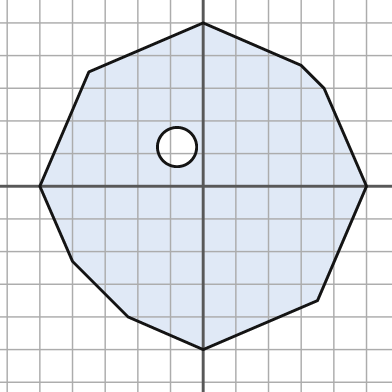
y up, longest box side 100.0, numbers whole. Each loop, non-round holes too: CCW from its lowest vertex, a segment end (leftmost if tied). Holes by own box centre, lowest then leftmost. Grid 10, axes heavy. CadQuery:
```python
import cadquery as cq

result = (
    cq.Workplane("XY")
    .moveTo(0.0, -50.0)
    .lineTo(35.0, -35.0)
    .lineTo(50.0, 0.0)
    .lineTo(37.0, 30.0)
    .lineTo(30.0, 37.0)
    .lineTo(0.0, 50.0)
    .lineTo(-35.0, 35.0)
    .lineTo(-50.0, 0.0)
    .lineTo(-40.0, -23.0)
    .lineTo(-23.0, -40.0)
    .close()
    .moveTo(-8.0, 12.0)
    .circle(6.0)
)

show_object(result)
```